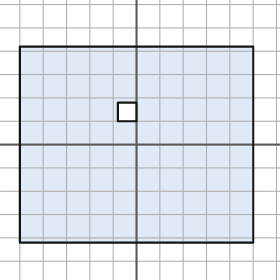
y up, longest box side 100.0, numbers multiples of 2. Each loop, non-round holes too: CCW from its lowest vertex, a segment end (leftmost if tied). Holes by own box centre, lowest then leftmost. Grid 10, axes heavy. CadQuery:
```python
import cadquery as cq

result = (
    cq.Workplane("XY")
    .moveTo(-50.0, -42.0)
    .lineTo(50.0, -42.0)
    .lineTo(50.0, 42.0)
    .lineTo(-50.0, 42.0)
    .close()
    .moveTo(-8.0, 10.0)
    .lineTo(0.0, 10.0)
    .lineTo(0.0, 18.0)
    .lineTo(-8.0, 18.0)
    .close()
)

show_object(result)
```